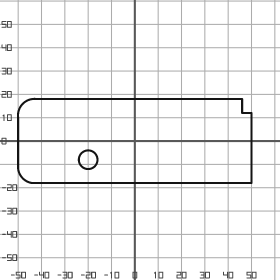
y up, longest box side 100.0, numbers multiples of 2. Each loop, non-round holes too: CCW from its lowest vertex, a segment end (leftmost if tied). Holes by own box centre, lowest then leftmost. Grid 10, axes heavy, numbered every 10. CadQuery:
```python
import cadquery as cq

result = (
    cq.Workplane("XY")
    .moveTo(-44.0, -18.0)
    .lineTo(50.0, -18.0)
    .lineTo(50.0, 12.0)
    .lineTo(46.0, 12.0)
    .lineTo(46.0, 18.0)
    .lineTo(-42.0, 18.0)
    .threePointArc((-48.0, 16.0), (-50.0, 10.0))
    .lineTo(-50.0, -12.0)
    .threePointArc((-48.0, -16.0), (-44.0, -18.0))
    .close()
    .moveTo(-20.0, -8.0)
    .circle(4.0)
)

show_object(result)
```